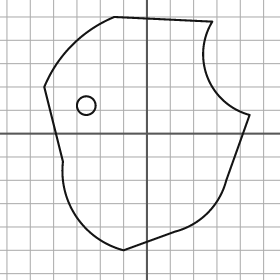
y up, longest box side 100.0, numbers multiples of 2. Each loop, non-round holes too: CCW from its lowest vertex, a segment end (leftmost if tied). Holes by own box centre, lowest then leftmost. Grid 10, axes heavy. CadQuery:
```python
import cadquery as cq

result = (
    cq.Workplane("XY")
    .moveTo(-10.0, -50.0)
    .lineTo(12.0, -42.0)
    .threePointArc((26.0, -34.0), (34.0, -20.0))
    .lineTo(44.0, 8.0)
    .threePointArc((26.0, 24.0), (28.0, 48.0))
    .lineTo(-14.0, 50.0)
    .threePointArc((-32.0, 38.0), (-44.0, 20.0))
    .lineTo(-36.0, -12.0)
    .threePointArc((-30.0, -36.0), (-10.0, -50.0))
    .close()
    .moveTo(-26.0, 12.0)
    .circle(4.0)
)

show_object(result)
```